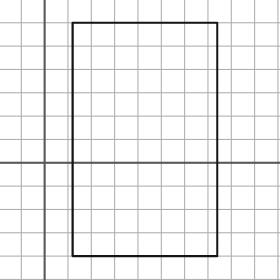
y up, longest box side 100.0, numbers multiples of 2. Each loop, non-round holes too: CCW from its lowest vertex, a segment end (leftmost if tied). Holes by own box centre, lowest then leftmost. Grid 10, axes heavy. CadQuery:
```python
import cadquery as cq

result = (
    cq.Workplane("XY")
    .moveTo(12.0, -40.0)
    .lineTo(74.0, -40.0)
    .lineTo(74.0, 60.0)
    .lineTo(12.0, 60.0)
    .close()
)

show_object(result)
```